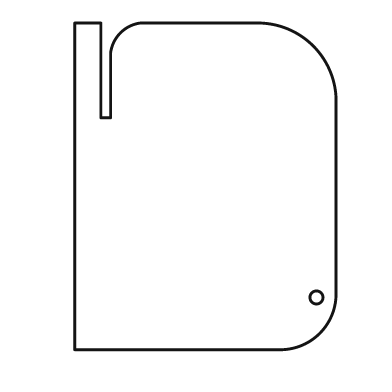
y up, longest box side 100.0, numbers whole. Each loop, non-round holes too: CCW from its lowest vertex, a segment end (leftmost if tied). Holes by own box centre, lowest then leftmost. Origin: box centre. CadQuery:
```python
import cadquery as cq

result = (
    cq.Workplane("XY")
    .moveTo(-40.0, -50.0)
    .lineTo(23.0, -50.0)
    .threePointArc((35.0, -45.0), (40.0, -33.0))
    .lineTo(40.0, 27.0)
    .threePointArc((33.0, 43.0), (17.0, 50.0))
    .lineTo(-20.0, 50.0)
    .threePointArc((-26.0, 47.0), (-29.0, 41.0))
    .lineTo(-29.0, 21.0)
    .lineTo(-32.0, 21.0)
    .lineTo(-32.0, 50.0)
    .lineTo(-40.0, 50.0)
    .close()
    .moveTo(34.0, -34.0)
    .circle(2.0)
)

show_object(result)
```